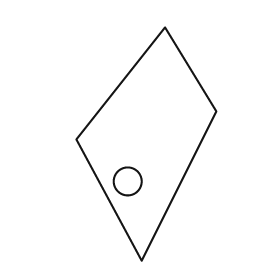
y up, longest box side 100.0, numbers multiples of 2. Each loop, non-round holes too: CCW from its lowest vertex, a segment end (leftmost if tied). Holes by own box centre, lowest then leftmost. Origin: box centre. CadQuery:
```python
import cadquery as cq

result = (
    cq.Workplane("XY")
    .moveTo(-2.0, -50.0)
    .lineTo(30.0, 14.0)
    .lineTo(8.0, 50.0)
    .lineTo(-30.0, 2.0)
    .close()
    .moveTo(-8.0, -16.0)
    .circle(6.0)
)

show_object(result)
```